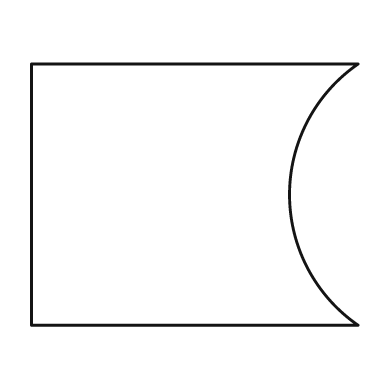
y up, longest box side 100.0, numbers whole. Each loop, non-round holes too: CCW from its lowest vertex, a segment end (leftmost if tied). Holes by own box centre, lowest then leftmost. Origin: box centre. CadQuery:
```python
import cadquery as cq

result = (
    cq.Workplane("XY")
    .moveTo(-50.0, -40.0)
    .lineTo(50.0, -40.0)
    .threePointArc((29.0, 0.0), (50.0, 40.0))
    .lineTo(-50.0, 40.0)
    .close()
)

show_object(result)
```